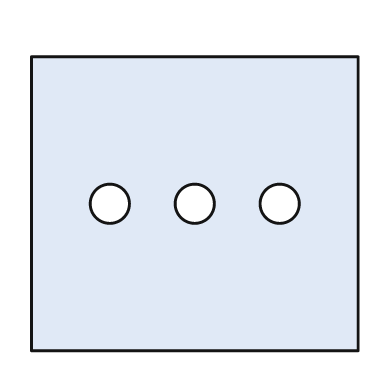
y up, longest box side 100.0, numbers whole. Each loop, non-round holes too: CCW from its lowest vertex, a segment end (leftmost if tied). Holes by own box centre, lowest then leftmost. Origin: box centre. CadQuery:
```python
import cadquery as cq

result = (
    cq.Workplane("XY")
    .moveTo(-50.0, -45.0)
    .lineTo(50.0, -45.0)
    .lineTo(50.0, 45.0)
    .lineTo(-50.0, 45.0)
    .close()
    .moveTo(-26.0, 0.0)
    .circle(6.0)
    .moveTo(0.0, 0.0)
    .circle(6.0)
    .moveTo(26.0, 0.0)
    .circle(6.0)
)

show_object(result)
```